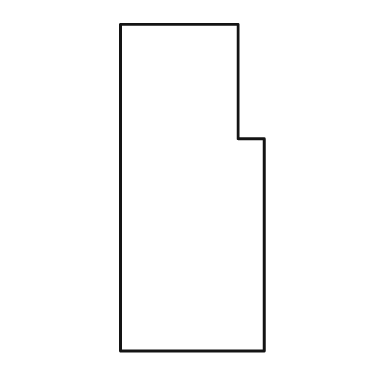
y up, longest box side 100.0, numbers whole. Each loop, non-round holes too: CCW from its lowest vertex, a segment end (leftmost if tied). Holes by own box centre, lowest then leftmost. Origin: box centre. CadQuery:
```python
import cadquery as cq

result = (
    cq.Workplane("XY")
    .moveTo(-22.0, -50.0)
    .lineTo(22.0, -50.0)
    .lineTo(22.0, 15.0)
    .lineTo(14.0, 15.0)
    .lineTo(14.0, 50.0)
    .lineTo(-22.0, 50.0)
    .close()
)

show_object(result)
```